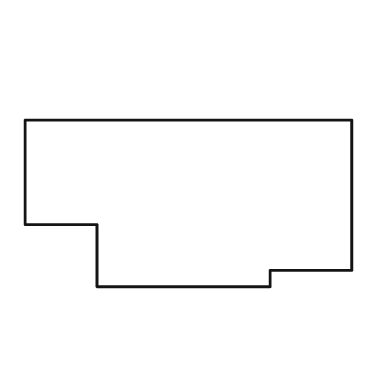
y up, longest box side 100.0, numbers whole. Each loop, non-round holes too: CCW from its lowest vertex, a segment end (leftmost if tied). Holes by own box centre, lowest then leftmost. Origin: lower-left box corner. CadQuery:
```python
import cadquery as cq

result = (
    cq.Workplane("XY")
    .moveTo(22.0, 0.0)
    .lineTo(75.0, 0.0)
    .lineTo(75.0, 5.0)
    .lineTo(100.0, 5.0)
    .lineTo(100.0, 51.0)
    .lineTo(0.0, 51.0)
    .lineTo(0.0, 19.0)
    .lineTo(22.0, 19.0)
    .close()
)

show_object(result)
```